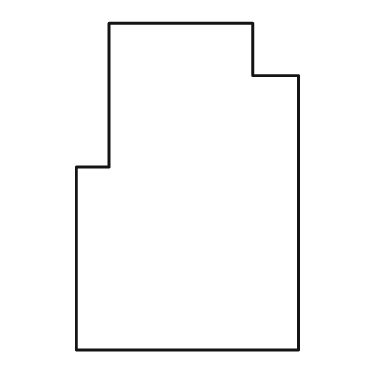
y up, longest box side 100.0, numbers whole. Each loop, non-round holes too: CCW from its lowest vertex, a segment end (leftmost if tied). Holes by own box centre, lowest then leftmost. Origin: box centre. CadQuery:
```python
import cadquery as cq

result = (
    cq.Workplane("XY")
    .moveTo(-34.0, -50.0)
    .lineTo(34.0, -50.0)
    .lineTo(34.0, 34.0)
    .lineTo(20.0, 34.0)
    .lineTo(20.0, 50.0)
    .lineTo(-24.0, 50.0)
    .lineTo(-24.0, 6.0)
    .lineTo(-34.0, 6.0)
    .close()
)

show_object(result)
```